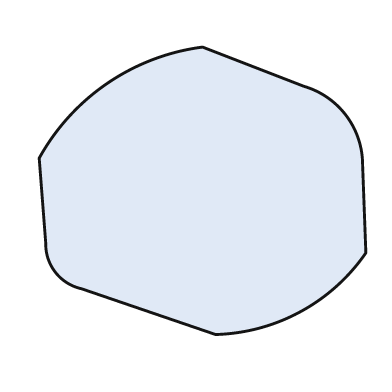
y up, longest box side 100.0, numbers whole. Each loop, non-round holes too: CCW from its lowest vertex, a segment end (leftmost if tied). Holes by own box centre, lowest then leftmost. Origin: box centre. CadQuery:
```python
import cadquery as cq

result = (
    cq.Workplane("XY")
    .moveTo(4.0, -44.0)
    .threePointArc((30.0, -37.0), (50.0, -19.0))
    .lineTo(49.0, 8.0)
    .threePointArc((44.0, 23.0), (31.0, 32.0))
    .lineTo(0.0, 44.0)
    .threePointArc((-29.0, 33.0), (-50.0, 10.0))
    .lineTo(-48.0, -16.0)
    .threePointArc((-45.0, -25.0), (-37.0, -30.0))
    .close()
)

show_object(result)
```